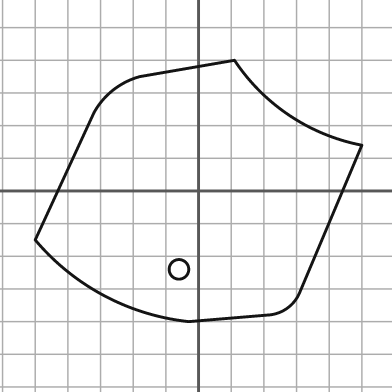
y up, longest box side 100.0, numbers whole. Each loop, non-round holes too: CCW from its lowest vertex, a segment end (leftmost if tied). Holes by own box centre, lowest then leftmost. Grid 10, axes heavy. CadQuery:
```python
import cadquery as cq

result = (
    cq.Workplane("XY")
    .moveTo(-3.0, -40.0)
    .lineTo(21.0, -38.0)
    .threePointArc((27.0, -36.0), (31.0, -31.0))
    .lineTo(50.0, 14.0)
    .threePointArc((28.0, 23.0), (11.0, 40.0))
    .lineTo(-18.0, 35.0)
    .threePointArc((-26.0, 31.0), (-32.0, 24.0))
    .lineTo(-50.0, -15.0)
    .threePointArc((-29.0, -32.0), (-3.0, -40.0))
    .close()
    .moveTo(-6.0, -24.0)
    .circle(3.0)
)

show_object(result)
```